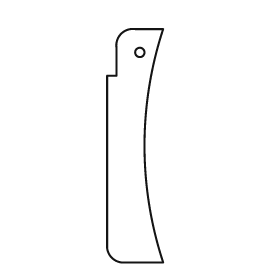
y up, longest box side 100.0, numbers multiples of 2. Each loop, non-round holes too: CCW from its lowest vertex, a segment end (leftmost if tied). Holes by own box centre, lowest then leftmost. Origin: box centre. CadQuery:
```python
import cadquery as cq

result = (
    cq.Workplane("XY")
    .moveTo(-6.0, -50.0)
    .lineTo(12.0, -50.0)
    .threePointArc((4.0, 0.0), (12.0, 50.0))
    .lineTo(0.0, 50.0)
    .threePointArc((-6.0, 48.0), (-8.0, 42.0))
    .lineTo(-8.0, 30.0)
    .lineTo(-12.0, 30.0)
    .lineTo(-12.0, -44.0)
    .threePointArc((-10.0, -48.0), (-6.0, -50.0))
    .close()
    .moveTo(2.0, 40.0)
    .circle(2.0)
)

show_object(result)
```